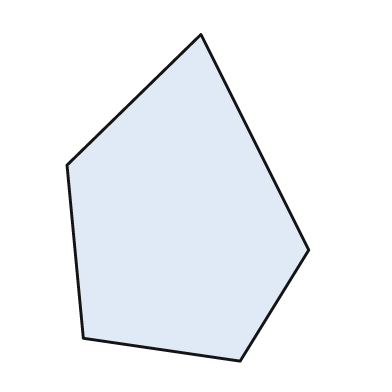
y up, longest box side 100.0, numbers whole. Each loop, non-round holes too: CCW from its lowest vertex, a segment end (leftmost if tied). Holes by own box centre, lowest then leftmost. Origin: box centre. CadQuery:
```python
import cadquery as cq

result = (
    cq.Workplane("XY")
    .moveTo(16.0, -50.0)
    .lineTo(37.0, -16.0)
    .lineTo(4.0, 50.0)
    .lineTo(-37.0, 10.0)
    .lineTo(-32.0, -43.0)
    .close()
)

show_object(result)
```